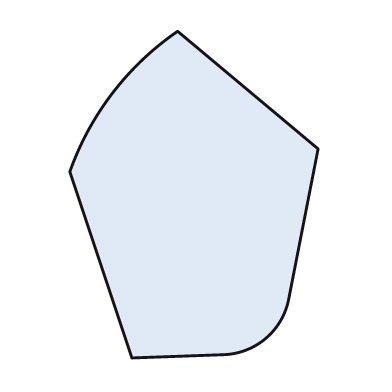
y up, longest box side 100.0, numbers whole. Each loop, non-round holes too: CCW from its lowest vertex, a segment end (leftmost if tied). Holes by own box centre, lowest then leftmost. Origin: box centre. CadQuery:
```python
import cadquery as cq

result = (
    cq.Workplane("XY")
    .moveTo(-19.0, -50.0)
    .lineTo(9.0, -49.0)
    .threePointArc((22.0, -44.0), (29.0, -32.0))
    .lineTo(38.0, 14.0)
    .lineTo(-5.0, 50.0)
    .threePointArc((-25.0, 31.0), (-38.0, 7.0))
    .close()
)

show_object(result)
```